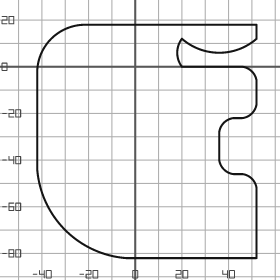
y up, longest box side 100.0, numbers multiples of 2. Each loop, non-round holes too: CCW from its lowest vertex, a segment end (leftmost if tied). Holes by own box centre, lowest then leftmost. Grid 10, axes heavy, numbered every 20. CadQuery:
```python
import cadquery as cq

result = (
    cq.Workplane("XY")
    .moveTo(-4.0, -82.0)
    .lineTo(52.0, -82.0)
    .lineTo(52.0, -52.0)
    .threePointArc((50.0, -48.0), (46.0, -46.0))
    .lineTo(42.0, -46.0)
    .threePointArc((38.0, -44.0), (36.0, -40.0))
    .lineTo(36.0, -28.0)
    .threePointArc((38.0, -24.0), (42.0, -22.0))
    .lineTo(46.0, -22.0)
    .threePointArc((50.0, -20.0), (52.0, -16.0))
    .lineTo(52.0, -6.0)
    .threePointArc((50.0, -2.0), (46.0, 0.0))
    .lineTo(20.0, 0.0)
    .threePointArc((18.0, 6.0), (20.0, 12.0))
    .threePointArc((36.0, 6.0), (52.0, 12.0))
    .lineTo(52.0, 18.0)
    .lineTo(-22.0, 18.0)
    .threePointArc((-36.0, 12.0), (-42.0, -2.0))
    .lineTo(-42.0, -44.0)
    .threePointArc((-30.0, -70.0), (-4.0, -82.0))
    .close()
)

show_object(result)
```